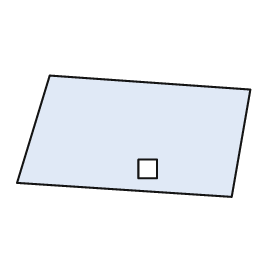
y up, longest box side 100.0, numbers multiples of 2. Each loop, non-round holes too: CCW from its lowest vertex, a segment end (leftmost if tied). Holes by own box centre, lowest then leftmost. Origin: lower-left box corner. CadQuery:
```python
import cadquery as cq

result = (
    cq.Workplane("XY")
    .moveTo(92.0, 0.0)
    .lineTo(100.0, 46.0)
    .lineTo(14.0, 52.0)
    .lineTo(0.0, 6.0)
    .close()
    .moveTo(52.0, 8.0)
    .lineTo(60.0, 8.0)
    .lineTo(60.0, 16.0)
    .lineTo(52.0, 16.0)
    .close()
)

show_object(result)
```